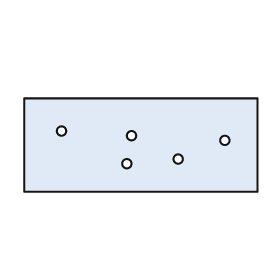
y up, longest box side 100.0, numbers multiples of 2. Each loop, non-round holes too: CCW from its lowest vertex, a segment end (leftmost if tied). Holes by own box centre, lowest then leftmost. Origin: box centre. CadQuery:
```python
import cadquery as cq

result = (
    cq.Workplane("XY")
    .moveTo(-50.0, -20.0)
    .lineTo(50.0, -20.0)
    .lineTo(50.0, 20.0)
    .lineTo(-50.0, 20.0)
    .close()
    .moveTo(-6.0, -8.0)
    .circle(2.0)
    .moveTo(16.0, -6.0)
    .circle(2.0)
    .moveTo(36.0, 2.0)
    .circle(2.0)
    .moveTo(-4.0, 4.0)
    .circle(2.0)
    .moveTo(-34.0, 6.0)
    .circle(2.0)
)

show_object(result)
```